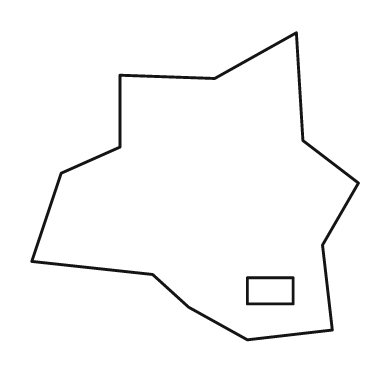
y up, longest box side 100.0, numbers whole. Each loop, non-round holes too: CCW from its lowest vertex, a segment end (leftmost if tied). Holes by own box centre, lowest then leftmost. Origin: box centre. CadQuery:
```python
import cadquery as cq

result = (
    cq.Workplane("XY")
    .moveTo(16.0, -47.0)
    .lineTo(42.0, -44.0)
    .lineTo(39.0, -18.0)
    .lineTo(50.0, 1.0)
    .lineTo(33.0, 14.0)
    .lineTo(31.0, 47.0)
    .lineTo(6.0, 33.0)
    .lineTo(-23.0, 34.0)
    .lineTo(-23.0, 12.0)
    .lineTo(-41.0, 4.0)
    .lineTo(-50.0, -23.0)
    .lineTo(-13.0, -27.0)
    .lineTo(-2.0, -37.0)
    .close()
    .moveTo(16.0, -36.0)
    .lineTo(30.0, -36.0)
    .lineTo(30.0, -28.0)
    .lineTo(16.0, -28.0)
    .close()
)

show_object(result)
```